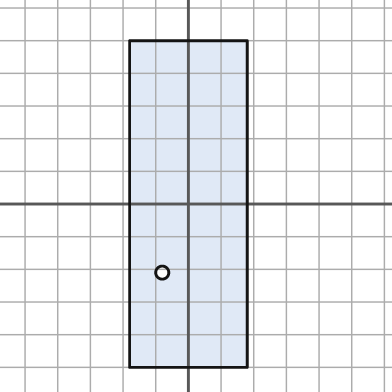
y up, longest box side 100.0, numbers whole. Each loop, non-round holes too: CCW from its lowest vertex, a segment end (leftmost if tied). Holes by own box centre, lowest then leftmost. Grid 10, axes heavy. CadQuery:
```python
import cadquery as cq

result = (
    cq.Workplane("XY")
    .moveTo(-18.0, -50.0)
    .lineTo(18.0, -50.0)
    .lineTo(18.0, 50.0)
    .lineTo(-18.0, 50.0)
    .close()
    .moveTo(-8.0, -21.0)
    .circle(2.0)
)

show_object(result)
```